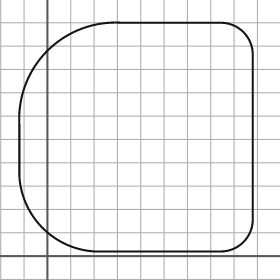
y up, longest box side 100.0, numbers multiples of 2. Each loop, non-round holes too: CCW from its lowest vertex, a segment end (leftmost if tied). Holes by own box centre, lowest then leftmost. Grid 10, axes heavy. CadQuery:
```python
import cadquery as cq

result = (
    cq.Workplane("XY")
    .moveTo(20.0, 2.0)
    .lineTo(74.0, 2.0)
    .threePointArc((84.0, 6.0), (88.0, 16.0))
    .lineTo(88.0, 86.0)
    .threePointArc((84.0, 96.0), (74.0, 100.0))
    .lineTo(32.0, 100.0)
    .threePointArc((0.0, 88.0), (-12.0, 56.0))
    .lineTo(-12.0, 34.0)
    .threePointArc((-2.0, 12.0), (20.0, 2.0))
    .close()
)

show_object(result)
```